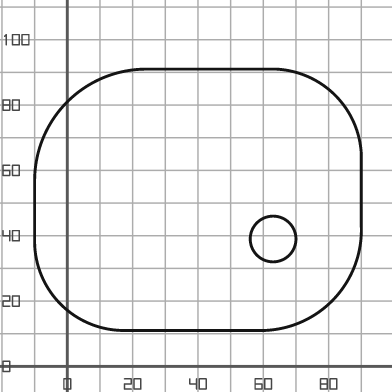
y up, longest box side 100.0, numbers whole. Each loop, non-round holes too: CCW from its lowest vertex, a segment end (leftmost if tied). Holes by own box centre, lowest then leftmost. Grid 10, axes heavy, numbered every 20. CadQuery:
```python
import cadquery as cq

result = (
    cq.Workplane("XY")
    .moveTo(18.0, 11.0)
    .lineTo(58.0, 11.0)
    .threePointArc((81.0, 20.0), (90.0, 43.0))
    .lineTo(90.0, 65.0)
    .threePointArc((82.0, 83.0), (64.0, 91.0))
    .lineTo(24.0, 91.0)
    .threePointArc((0.0, 81.0), (-10.0, 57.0))
    .lineTo(-10.0, 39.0)
    .threePointArc((-2.0, 19.0), (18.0, 11.0))
    .close()
    .moveTo(63.0, 39.0)
    .circle(7.0)
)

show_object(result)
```